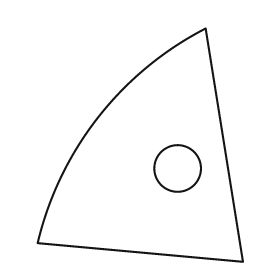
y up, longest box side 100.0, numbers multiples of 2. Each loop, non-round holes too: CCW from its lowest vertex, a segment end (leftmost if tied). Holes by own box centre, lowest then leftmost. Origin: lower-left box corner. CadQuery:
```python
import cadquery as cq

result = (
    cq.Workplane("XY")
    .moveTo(88.0, 0.0)
    .lineTo(72.0, 100.0)
    .threePointArc((26.0, 62.0), (0.0, 8.0))
    .close()
    .moveTo(60.0, 40.0)
    .circle(10.0)
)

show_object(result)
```